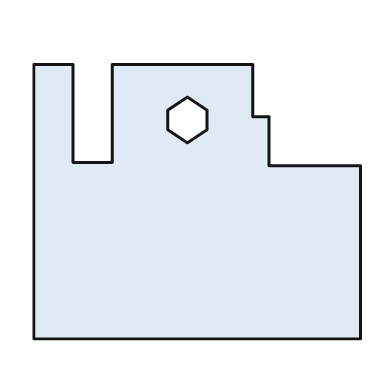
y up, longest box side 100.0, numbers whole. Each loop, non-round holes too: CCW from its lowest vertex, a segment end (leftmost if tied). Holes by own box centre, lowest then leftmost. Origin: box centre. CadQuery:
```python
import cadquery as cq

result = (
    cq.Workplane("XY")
    .moveTo(-50.0, -42.0)
    .lineTo(50.0, -42.0)
    .lineTo(50.0, 11.0)
    .lineTo(22.0, 11.0)
    .lineTo(22.0, 26.0)
    .lineTo(17.0, 26.0)
    .lineTo(17.0, 42.0)
    .lineTo(-26.0, 42.0)
    .lineTo(-26.0, 12.0)
    .lineTo(-38.0, 12.0)
    .lineTo(-38.0, 42.0)
    .lineTo(-50.0, 42.0)
    .close()
    .moveTo(-3.0, 18.0)
    .lineTo(3.0, 22.0)
    .lineTo(3.0, 28.0)
    .lineTo(-3.0, 32.0)
    .lineTo(-9.0, 28.0)
    .lineTo(-9.0, 22.0)
    .close()
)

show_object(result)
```